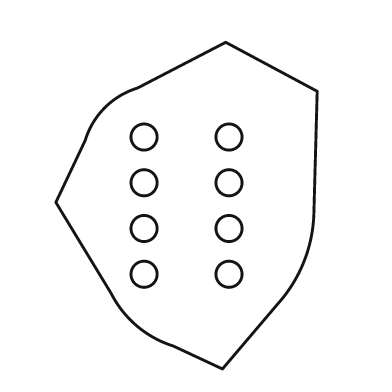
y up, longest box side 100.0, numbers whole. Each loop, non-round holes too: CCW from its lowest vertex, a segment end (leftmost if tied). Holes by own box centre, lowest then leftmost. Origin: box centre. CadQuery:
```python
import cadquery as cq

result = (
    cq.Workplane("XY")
    .moveTo(11.0, -50.0)
    .lineTo(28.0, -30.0)
    .threePointArc((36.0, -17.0), (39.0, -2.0))
    .lineTo(40.0, 35.0)
    .lineTo(12.0, 50.0)
    .lineTo(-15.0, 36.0)
    .threePointArc((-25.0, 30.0), (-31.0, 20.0))
    .lineTo(-40.0, 1.0)
    .lineTo(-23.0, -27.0)
    .threePointArc((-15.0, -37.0), (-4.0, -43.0))
    .close()
    .moveTo(-13.0, -21.0)
    .circle(4.0)
    .moveTo(13.0, -21.0)
    .circle(4.0)
    .moveTo(-13.0, -7.0)
    .circle(4.0)
    .moveTo(13.0, -7.0)
    .circle(4.0)
    .moveTo(-13.0, 7.0)
    .circle(4.0)
    .moveTo(13.0, 7.0)
    .circle(4.0)
    .moveTo(-13.0, 21.0)
    .circle(4.0)
    .moveTo(13.0, 21.0)
    .circle(4.0)
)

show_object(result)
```